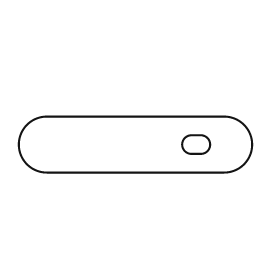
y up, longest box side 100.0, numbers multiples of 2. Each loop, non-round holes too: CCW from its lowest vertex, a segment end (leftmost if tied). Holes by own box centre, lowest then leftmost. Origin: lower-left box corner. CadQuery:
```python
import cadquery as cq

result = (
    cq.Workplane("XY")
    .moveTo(12.0, 0.0)
    .lineTo(88.0, 0.0)
    .threePointArc((100.0, 12.0), (88.0, 24.0))
    .lineTo(12.0, 24.0)
    .threePointArc((0.0, 12.0), (12.0, 0.0))
    .close()
    .moveTo(74.0, 8.0)
    .lineTo(78.0, 8.0)
    .threePointArc((82.0, 12.0), (78.0, 16.0))
    .lineTo(74.0, 16.0)
    .threePointArc((70.0, 12.0), (74.0, 8.0))
    .close()
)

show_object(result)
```